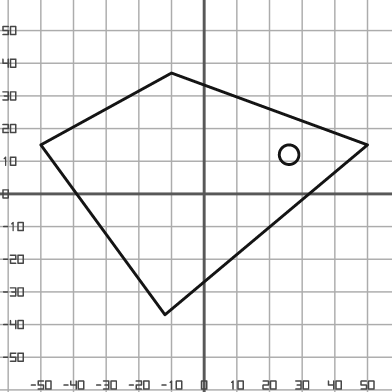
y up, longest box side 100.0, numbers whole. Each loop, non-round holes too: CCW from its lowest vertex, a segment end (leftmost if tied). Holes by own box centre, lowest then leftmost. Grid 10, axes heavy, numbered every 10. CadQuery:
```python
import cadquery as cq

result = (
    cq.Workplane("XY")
    .moveTo(-12.0, -37.0)
    .lineTo(50.0, 15.0)
    .lineTo(-10.0, 37.0)
    .lineTo(-50.0, 15.0)
    .close()
    .moveTo(26.0, 12.0)
    .circle(3.0)
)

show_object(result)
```